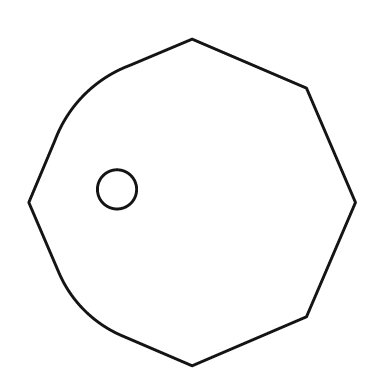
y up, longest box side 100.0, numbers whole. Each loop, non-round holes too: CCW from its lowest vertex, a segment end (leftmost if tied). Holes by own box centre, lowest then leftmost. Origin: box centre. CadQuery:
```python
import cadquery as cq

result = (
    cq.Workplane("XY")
    .moveTo(0.0, -50.0)
    .lineTo(35.0, -35.0)
    .lineTo(50.0, 0.0)
    .lineTo(35.0, 35.0)
    .lineTo(0.0, 50.0)
    .lineTo(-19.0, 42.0)
    .threePointArc((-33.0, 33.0), (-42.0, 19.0))
    .lineTo(-50.0, 0.0)
    .lineTo(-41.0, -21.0)
    .threePointArc((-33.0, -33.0), (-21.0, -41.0))
    .close()
    .moveTo(-23.0, 4.0)
    .circle(6.0)
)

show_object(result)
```